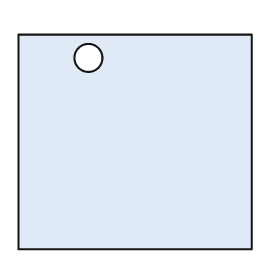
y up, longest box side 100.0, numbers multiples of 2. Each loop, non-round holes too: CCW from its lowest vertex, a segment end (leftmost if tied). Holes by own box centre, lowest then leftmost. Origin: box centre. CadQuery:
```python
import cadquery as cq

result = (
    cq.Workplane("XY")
    .moveTo(-50.0, -46.0)
    .lineTo(50.0, -46.0)
    .lineTo(50.0, 46.0)
    .lineTo(-50.0, 46.0)
    .close()
    .moveTo(-20.0, 36.0)
    .circle(6.0)
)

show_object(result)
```